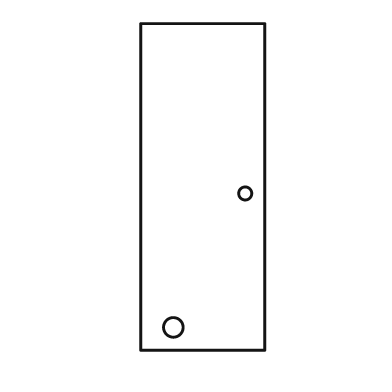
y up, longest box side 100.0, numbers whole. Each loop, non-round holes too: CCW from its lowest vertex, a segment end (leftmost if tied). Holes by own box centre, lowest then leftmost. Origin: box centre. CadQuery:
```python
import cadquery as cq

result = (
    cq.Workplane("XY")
    .moveTo(-19.0, -50.0)
    .lineTo(19.0, -50.0)
    .lineTo(19.0, 50.0)
    .lineTo(-19.0, 50.0)
    .close()
    .moveTo(-9.0, -43.0)
    .circle(3.0)
    .moveTo(13.0, -2.0)
    .circle(2.0)
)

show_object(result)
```